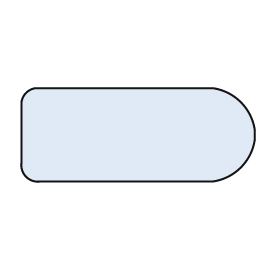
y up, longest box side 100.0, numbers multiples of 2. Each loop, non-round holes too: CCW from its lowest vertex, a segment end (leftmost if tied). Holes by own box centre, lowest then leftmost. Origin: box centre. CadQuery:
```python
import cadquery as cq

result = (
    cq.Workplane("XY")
    .moveTo(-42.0, -20.0)
    .lineTo(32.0, -20.0)
    .threePointArc((44.0, -14.0), (50.0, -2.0))
    .lineTo(50.0, 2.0)
    .threePointArc((44.0, 14.0), (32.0, 20.0))
    .lineTo(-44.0, 20.0)
    .threePointArc((-48.0, 18.0), (-50.0, 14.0))
    .lineTo(-50.0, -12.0)
    .threePointArc((-48.0, -18.0), (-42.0, -20.0))
    .close()
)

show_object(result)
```